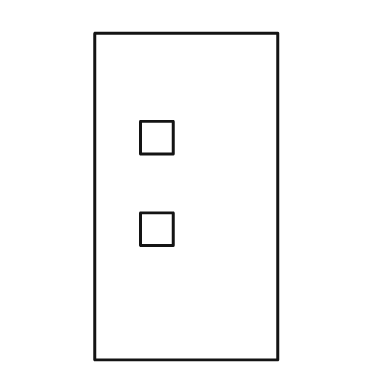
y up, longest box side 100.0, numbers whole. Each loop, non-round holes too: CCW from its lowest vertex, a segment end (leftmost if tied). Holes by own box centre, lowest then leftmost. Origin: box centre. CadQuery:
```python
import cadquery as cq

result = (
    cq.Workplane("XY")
    .moveTo(-28.0, -50.0)
    .lineTo(28.0, -50.0)
    .lineTo(28.0, 50.0)
    .lineTo(-28.0, 50.0)
    .close()
    .moveTo(-14.0, -15.0)
    .lineTo(-4.0, -15.0)
    .lineTo(-4.0, -5.0)
    .lineTo(-14.0, -5.0)
    .close()
    .moveTo(-14.0, 13.0)
    .lineTo(-4.0, 13.0)
    .lineTo(-4.0, 23.0)
    .lineTo(-14.0, 23.0)
    .close()
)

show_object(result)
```